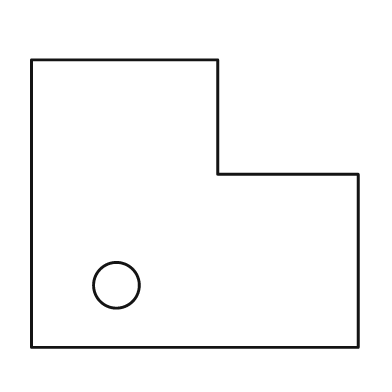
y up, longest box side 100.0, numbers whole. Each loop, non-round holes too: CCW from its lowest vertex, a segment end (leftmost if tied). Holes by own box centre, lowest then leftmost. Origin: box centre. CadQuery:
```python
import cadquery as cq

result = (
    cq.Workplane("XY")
    .moveTo(-50.0, -44.0)
    .lineTo(50.0, -44.0)
    .lineTo(50.0, 9.0)
    .lineTo(7.0, 9.0)
    .lineTo(7.0, 44.0)
    .lineTo(-50.0, 44.0)
    .close()
    .moveTo(-24.0, -25.0)
    .circle(7.0)
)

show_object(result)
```